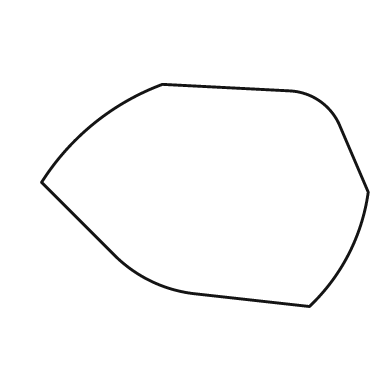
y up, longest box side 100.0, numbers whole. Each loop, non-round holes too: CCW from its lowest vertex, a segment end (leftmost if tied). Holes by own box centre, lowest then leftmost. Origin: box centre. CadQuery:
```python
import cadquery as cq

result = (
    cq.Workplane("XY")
    .moveTo(32.0, -34.0)
    .threePointArc((44.0, -18.0), (50.0, 1.0))
    .lineTo(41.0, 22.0)
    .threePointArc((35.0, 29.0), (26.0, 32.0))
    .lineTo(-13.0, 34.0)
    .threePointArc((-34.0, 22.0), (-50.0, 4.0))
    .lineTo(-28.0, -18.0)
    .threePointArc((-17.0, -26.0), (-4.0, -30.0))
    .close()
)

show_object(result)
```